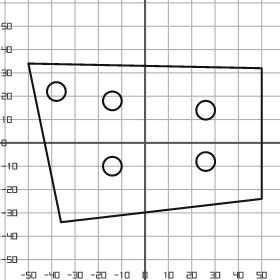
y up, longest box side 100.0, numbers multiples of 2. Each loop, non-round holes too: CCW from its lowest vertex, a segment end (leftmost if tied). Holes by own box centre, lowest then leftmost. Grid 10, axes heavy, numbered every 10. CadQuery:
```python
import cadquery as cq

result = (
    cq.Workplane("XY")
    .moveTo(-36.0, -34.0)
    .lineTo(50.0, -24.0)
    .lineTo(50.0, 32.0)
    .lineTo(-50.0, 34.0)
    .close()
    .moveTo(-14.0, -10.0)
    .circle(4.0)
    .moveTo(26.0, -8.0)
    .circle(4.0)
    .moveTo(26.0, 14.0)
    .circle(4.0)
    .moveTo(-14.0, 18.0)
    .circle(4.0)
    .moveTo(-38.0, 22.0)
    .circle(4.0)
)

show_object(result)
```